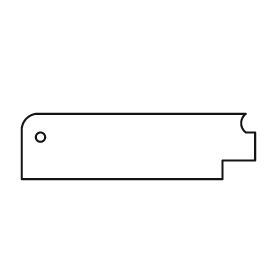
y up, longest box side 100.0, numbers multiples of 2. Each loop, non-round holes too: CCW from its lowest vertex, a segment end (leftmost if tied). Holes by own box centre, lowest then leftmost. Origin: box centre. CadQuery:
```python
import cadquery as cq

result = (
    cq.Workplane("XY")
    .moveTo(-50.0, -14.0)
    .lineTo(36.0, -14.0)
    .lineTo(36.0, -6.0)
    .lineTo(50.0, -6.0)
    .lineTo(50.0, 6.0)
    .lineTo(46.0, 6.0)
    .threePointArc((44.0, 10.0), (46.0, 14.0))
    .lineTo(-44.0, 14.0)
    .threePointArc((-48.0, 12.0), (-50.0, 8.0))
    .close()
    .moveTo(-42.0, 4.0)
    .circle(2.0)
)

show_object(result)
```